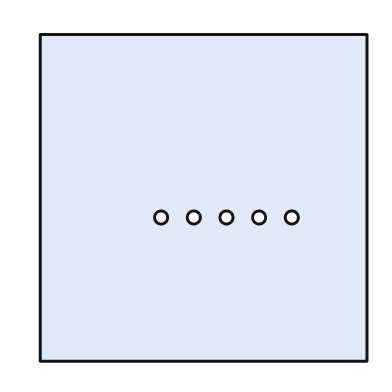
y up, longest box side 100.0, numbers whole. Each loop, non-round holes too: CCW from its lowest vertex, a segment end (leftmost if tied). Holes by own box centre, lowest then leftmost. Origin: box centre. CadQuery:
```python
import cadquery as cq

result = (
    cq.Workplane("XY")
    .moveTo(-50.0, -50.0)
    .lineTo(50.0, -50.0)
    .lineTo(50.0, 50.0)
    .lineTo(-50.0, 50.0)
    .close()
    .moveTo(-13.0, -6.0)
    .circle(2.0)
    .moveTo(-3.0, -6.0)
    .circle(2.0)
    .moveTo(7.0, -6.0)
    .circle(2.0)
    .moveTo(17.0, -6.0)
    .circle(2.0)
    .moveTo(27.0, -6.0)
    .circle(2.0)
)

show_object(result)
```